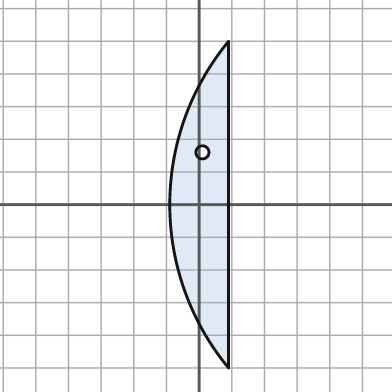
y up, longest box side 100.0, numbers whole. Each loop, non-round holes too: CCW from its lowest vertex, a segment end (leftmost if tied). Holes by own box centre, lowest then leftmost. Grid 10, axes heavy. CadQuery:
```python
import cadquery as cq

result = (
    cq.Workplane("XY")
    .moveTo(9.0, -50.0)
    .lineTo(9.0, 50.0)
    .threePointArc((-9.0, 0.0), (9.0, -50.0))
    .close()
    .moveTo(1.0, 16.0)
    .circle(2.0)
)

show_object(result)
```